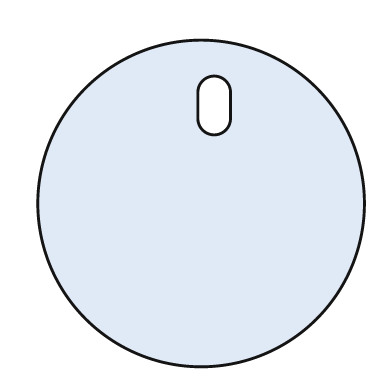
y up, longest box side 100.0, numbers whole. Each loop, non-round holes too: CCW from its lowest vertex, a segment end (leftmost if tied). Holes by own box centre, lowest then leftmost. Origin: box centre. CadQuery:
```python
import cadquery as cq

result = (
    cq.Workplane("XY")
    .moveTo(0.0, 0.0)
    .circle(50.0)
    .moveTo(-1.0, 26.0)
    .threePointArc((4.0, 21.0), (9.0, 26.0))
    .lineTo(9.0, 34.0)
    .threePointArc((4.0, 39.0), (-1.0, 34.0))
    .close()
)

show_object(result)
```